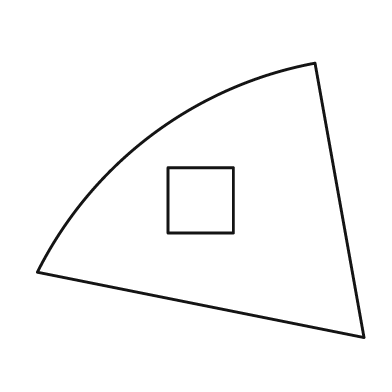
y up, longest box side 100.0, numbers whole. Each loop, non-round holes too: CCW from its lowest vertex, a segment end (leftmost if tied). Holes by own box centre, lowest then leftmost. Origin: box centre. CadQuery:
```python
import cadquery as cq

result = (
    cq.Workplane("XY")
    .moveTo(50.0, -42.0)
    .lineTo(35.0, 42.0)
    .threePointArc((-15.0, 20.0), (-50.0, -22.0))
    .close()
    .moveTo(-10.0, -10.0)
    .lineTo(10.0, -10.0)
    .lineTo(10.0, 10.0)
    .lineTo(-10.0, 10.0)
    .close()
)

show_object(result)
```